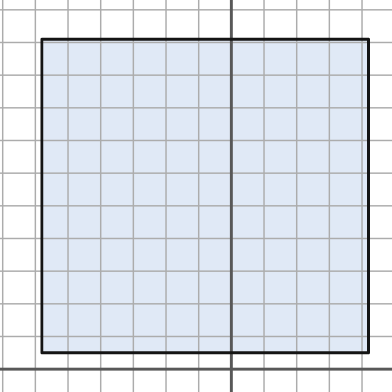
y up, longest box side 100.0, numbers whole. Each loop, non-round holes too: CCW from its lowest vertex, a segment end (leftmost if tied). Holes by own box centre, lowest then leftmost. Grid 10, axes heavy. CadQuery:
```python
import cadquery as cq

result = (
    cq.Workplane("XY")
    .moveTo(-58.0, 5.0)
    .lineTo(42.0, 5.0)
    .lineTo(42.0, 101.0)
    .lineTo(-58.0, 101.0)
    .close()
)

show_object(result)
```